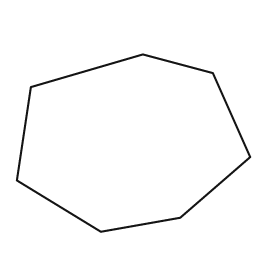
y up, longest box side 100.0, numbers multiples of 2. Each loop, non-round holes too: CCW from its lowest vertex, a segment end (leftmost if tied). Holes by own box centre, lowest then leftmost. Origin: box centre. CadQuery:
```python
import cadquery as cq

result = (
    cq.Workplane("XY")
    .moveTo(-14.0, -38.0)
    .lineTo(20.0, -32.0)
    .lineTo(50.0, -6.0)
    .lineTo(34.0, 30.0)
    .lineTo(4.0, 38.0)
    .lineTo(-44.0, 24.0)
    .lineTo(-50.0, -16.0)
    .close()
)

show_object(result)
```